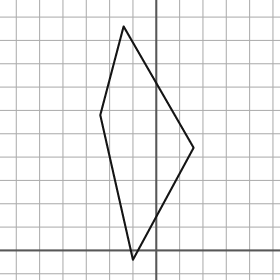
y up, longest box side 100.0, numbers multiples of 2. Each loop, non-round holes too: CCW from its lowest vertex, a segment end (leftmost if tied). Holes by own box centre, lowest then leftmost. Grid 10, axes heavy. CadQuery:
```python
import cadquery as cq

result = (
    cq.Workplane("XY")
    .moveTo(-10.0, -4.0)
    .lineTo(16.0, 44.0)
    .lineTo(-14.0, 96.0)
    .lineTo(-24.0, 58.0)
    .close()
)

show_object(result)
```